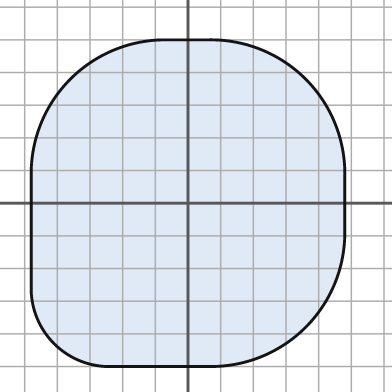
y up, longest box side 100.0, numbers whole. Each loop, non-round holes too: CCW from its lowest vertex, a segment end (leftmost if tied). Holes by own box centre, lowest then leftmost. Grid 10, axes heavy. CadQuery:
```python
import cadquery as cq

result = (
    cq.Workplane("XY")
    .moveTo(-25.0, -50.0)
    .lineTo(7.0, -50.0)
    .threePointArc((36.0, -38.0), (48.0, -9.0))
    .lineTo(48.0, 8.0)
    .threePointArc((36.0, 38.0), (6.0, 50.0))
    .lineTo(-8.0, 50.0)
    .threePointArc((-36.0, 38.0), (-48.0, 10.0))
    .lineTo(-48.0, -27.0)
    .threePointArc((-41.0, -43.0), (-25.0, -50.0))
    .close()
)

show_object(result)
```